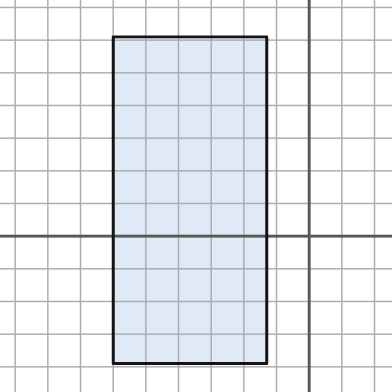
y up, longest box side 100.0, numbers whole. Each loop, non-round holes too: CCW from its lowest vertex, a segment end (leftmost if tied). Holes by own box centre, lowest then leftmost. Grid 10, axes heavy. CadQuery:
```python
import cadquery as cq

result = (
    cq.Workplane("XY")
    .moveTo(-60.0, -39.0)
    .lineTo(-13.0, -39.0)
    .lineTo(-13.0, 61.0)
    .lineTo(-60.0, 61.0)
    .close()
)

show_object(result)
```